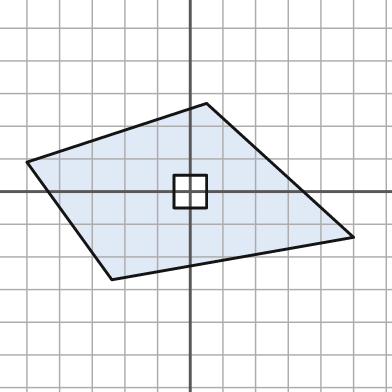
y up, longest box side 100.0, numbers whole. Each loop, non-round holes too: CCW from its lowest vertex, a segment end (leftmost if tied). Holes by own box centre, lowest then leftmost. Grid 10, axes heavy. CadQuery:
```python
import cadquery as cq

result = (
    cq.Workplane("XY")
    .moveTo(-24.0, -27.0)
    .lineTo(50.0, -14.0)
    .lineTo(5.0, 27.0)
    .lineTo(-50.0, 9.0)
    .close()
    .moveTo(-5.0, -5.0)
    .lineTo(5.0, -5.0)
    .lineTo(5.0, 5.0)
    .lineTo(-5.0, 5.0)
    .close()
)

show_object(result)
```